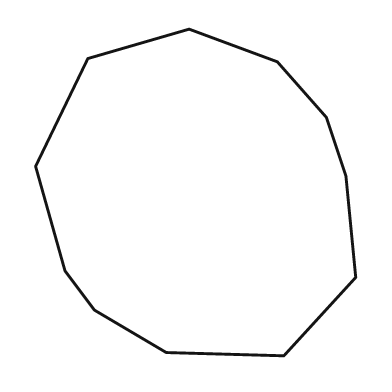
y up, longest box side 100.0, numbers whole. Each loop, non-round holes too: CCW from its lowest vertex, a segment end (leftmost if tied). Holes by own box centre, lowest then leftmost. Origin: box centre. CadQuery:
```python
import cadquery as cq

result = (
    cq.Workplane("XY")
    .moveTo(27.0, -50.0)
    .lineTo(49.0, -26.0)
    .lineTo(46.0, 5.0)
    .lineTo(40.0, 23.0)
    .lineTo(25.0, 40.0)
    .lineTo(-2.0, 50.0)
    .lineTo(-33.0, 41.0)
    .lineTo(-49.0, 8.0)
    .lineTo(-40.0, -24.0)
    .lineTo(-31.0, -36.0)
    .lineTo(-9.0, -49.0)
    .close()
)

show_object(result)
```